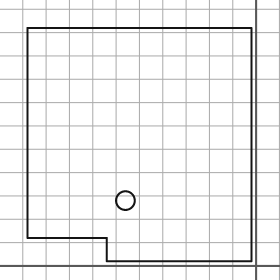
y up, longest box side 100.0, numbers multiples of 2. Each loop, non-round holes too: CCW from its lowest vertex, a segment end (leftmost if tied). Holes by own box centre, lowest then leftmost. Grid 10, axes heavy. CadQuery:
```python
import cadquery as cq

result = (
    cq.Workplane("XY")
    .moveTo(-64.0, 2.0)
    .lineTo(-2.0, 2.0)
    .lineTo(-2.0, 102.0)
    .lineTo(-98.0, 102.0)
    .lineTo(-98.0, 12.0)
    .lineTo(-64.0, 12.0)
    .close()
    .moveTo(-56.0, 28.0)
    .circle(4.0)
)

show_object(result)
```